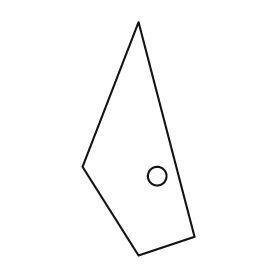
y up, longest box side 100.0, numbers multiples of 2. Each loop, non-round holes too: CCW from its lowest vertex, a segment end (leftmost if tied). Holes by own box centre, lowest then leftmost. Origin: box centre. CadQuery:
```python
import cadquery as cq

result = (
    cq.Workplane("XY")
    .moveTo(0.0, -50.0)
    .lineTo(24.0, -42.0)
    .lineTo(0.0, 50.0)
    .lineTo(-24.0, -12.0)
    .close()
    .moveTo(8.0, -16.0)
    .circle(4.0)
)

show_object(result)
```